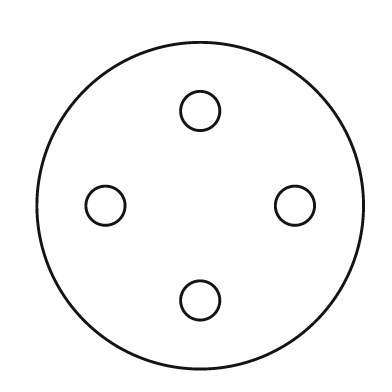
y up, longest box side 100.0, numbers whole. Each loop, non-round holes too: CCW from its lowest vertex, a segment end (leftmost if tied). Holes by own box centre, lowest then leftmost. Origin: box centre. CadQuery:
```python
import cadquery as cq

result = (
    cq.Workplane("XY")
    .moveTo(0.0, 0.0)
    .circle(50.0)
    .moveTo(0.0, -29.0)
    .circle(6.0)
    .moveTo(-29.0, 0.0)
    .circle(6.0)
    .moveTo(29.0, 0.0)
    .circle(6.0)
    .moveTo(0.0, 29.0)
    .circle(6.0)
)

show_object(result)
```